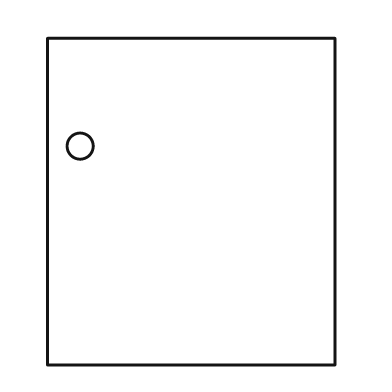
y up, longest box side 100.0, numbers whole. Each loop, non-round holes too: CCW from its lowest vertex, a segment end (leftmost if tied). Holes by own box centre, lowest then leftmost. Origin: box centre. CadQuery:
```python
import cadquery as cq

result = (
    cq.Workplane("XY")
    .moveTo(-44.0, -50.0)
    .lineTo(44.0, -50.0)
    .lineTo(44.0, 50.0)
    .lineTo(-44.0, 50.0)
    .close()
    .moveTo(-34.0, 17.0)
    .circle(4.0)
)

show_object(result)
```